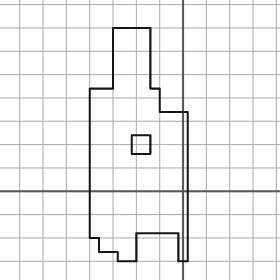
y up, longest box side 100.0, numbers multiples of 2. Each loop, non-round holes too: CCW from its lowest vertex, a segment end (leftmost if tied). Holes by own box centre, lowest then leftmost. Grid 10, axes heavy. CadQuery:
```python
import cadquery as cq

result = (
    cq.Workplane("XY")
    .moveTo(-28.0, -30.0)
    .lineTo(-20.0, -30.0)
    .lineTo(-20.0, -18.0)
    .lineTo(-2.0, -18.0)
    .lineTo(-2.0, -30.0)
    .lineTo(2.0, -30.0)
    .lineTo(2.0, 34.0)
    .lineTo(-10.0, 34.0)
    .lineTo(-10.0, 44.0)
    .lineTo(-14.0, 44.0)
    .lineTo(-14.0, 70.0)
    .lineTo(-30.0, 70.0)
    .lineTo(-30.0, 44.0)
    .lineTo(-40.0, 44.0)
    .lineTo(-40.0, -20.0)
    .lineTo(-36.0, -20.0)
    .lineTo(-36.0, -26.0)
    .lineTo(-28.0, -26.0)
    .close()
    .moveTo(-22.0, 16.0)
    .lineTo(-14.0, 16.0)
    .lineTo(-14.0, 24.0)
    .lineTo(-22.0, 24.0)
    .close()
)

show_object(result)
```